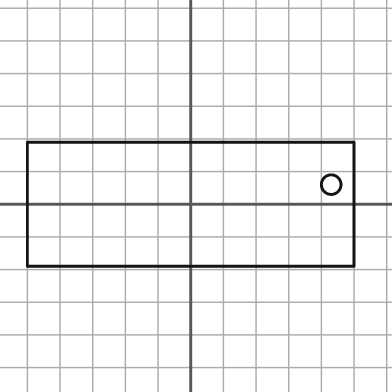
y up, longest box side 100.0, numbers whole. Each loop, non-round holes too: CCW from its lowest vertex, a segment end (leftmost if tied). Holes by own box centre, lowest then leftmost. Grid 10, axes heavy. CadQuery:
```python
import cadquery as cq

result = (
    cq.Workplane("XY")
    .moveTo(-50.0, -19.0)
    .lineTo(50.0, -19.0)
    .lineTo(50.0, 19.0)
    .lineTo(-50.0, 19.0)
    .close()
    .moveTo(43.0, 6.0)
    .circle(3.0)
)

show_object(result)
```